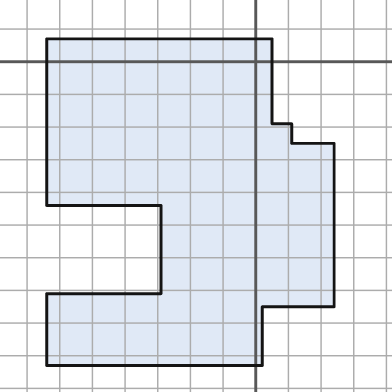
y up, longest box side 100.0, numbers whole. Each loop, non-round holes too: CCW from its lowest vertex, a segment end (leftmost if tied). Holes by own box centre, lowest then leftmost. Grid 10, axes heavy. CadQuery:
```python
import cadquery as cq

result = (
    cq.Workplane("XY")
    .moveTo(-64.0, -93.0)
    .lineTo(2.0, -93.0)
    .lineTo(2.0, -75.0)
    .lineTo(24.0, -75.0)
    .lineTo(24.0, -25.0)
    .lineTo(11.0, -25.0)
    .lineTo(11.0, -19.0)
    .lineTo(5.0, -19.0)
    .lineTo(5.0, 7.0)
    .lineTo(-64.0, 7.0)
    .lineTo(-64.0, -44.0)
    .lineTo(-29.0, -44.0)
    .lineTo(-29.0, -71.0)
    .lineTo(-64.0, -71.0)
    .close()
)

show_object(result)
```